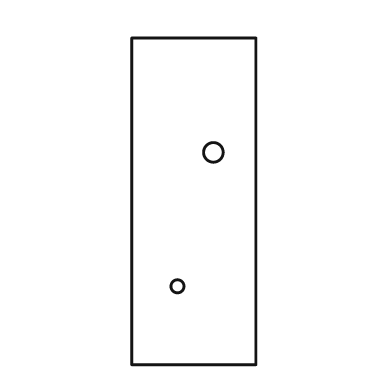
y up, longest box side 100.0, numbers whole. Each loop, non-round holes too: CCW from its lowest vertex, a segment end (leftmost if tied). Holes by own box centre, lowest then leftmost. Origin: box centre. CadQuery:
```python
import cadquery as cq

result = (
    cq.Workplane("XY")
    .moveTo(-19.0, -50.0)
    .lineTo(19.0, -50.0)
    .lineTo(19.0, 50.0)
    .lineTo(-19.0, 50.0)
    .close()
    .moveTo(-5.0, -26.0)
    .circle(2.0)
    .moveTo(6.0, 15.0)
    .circle(3.0)
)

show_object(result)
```